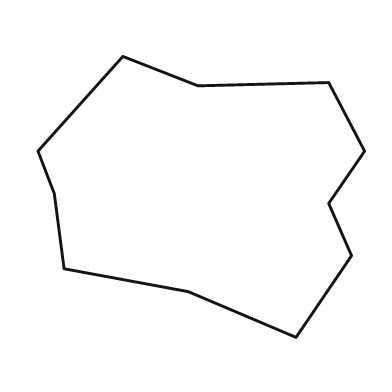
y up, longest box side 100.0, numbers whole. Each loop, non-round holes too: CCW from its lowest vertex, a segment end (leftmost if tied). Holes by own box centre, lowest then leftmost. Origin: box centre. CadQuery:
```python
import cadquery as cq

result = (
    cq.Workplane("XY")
    .moveTo(29.0, -43.0)
    .lineTo(46.0, -18.0)
    .lineTo(39.0, -2.0)
    .lineTo(50.0, 14.0)
    .lineTo(39.0, 35.0)
    .lineTo(-1.0, 34.0)
    .lineTo(-24.0, 43.0)
    .lineTo(-50.0, 14.0)
    .lineTo(-45.0, 1.0)
    .lineTo(-42.0, -22.0)
    .lineTo(-4.0, -29.0)
    .close()
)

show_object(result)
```